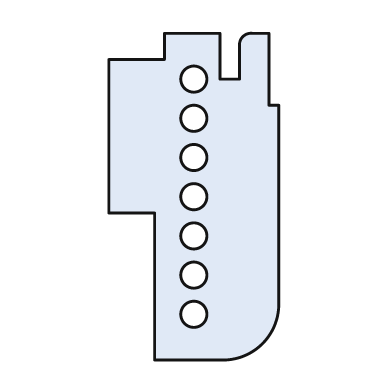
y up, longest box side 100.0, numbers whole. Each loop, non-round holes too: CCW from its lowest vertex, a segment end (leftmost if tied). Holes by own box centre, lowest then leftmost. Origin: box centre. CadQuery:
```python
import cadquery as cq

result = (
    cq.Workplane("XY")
    .moveTo(-12.0, -50.0)
    .lineTo(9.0, -50.0)
    .threePointArc((21.0, -45.0), (26.0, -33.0))
    .lineTo(26.0, 28.0)
    .lineTo(23.0, 28.0)
    .lineTo(23.0, 50.0)
    .lineTo(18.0, 50.0)
    .threePointArc((15.0, 49.0), (14.0, 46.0))
    .lineTo(14.0, 36.0)
    .lineTo(8.0, 36.0)
    .lineTo(8.0, 50.0)
    .lineTo(-9.0, 50.0)
    .lineTo(-9.0, 42.0)
    .lineTo(-26.0, 42.0)
    .lineTo(-26.0, -5.0)
    .lineTo(-12.0, -5.0)
    .close()
    .moveTo(0.0, -36.0)
    .circle(4.0)
    .moveTo(0.0, -24.0)
    .circle(4.0)
    .moveTo(0.0, -12.0)
    .circle(4.0)
    .moveTo(0.0, 0.0)
    .circle(4.0)
    .moveTo(0.0, 12.0)
    .circle(4.0)
    .moveTo(0.0, 24.0)
    .circle(4.0)
    .moveTo(0.0, 36.0)
    .circle(4.0)
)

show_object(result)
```